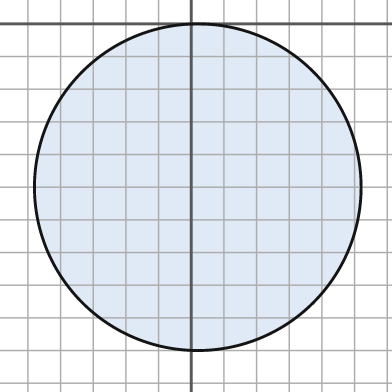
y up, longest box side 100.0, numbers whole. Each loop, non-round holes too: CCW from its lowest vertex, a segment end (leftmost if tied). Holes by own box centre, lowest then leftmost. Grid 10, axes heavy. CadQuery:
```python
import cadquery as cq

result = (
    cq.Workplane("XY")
    .moveTo(2.0, -50.0)
    .circle(50.0)
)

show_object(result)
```